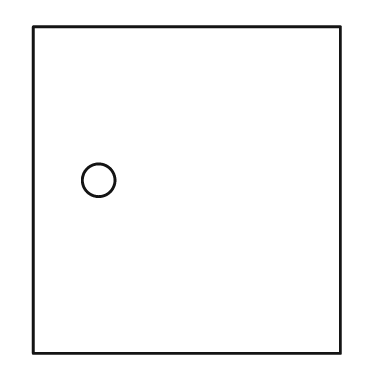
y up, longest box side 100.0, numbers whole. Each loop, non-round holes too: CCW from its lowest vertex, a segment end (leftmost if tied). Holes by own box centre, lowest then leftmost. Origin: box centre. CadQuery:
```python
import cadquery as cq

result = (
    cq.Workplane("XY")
    .moveTo(-47.0, -50.0)
    .lineTo(47.0, -50.0)
    .lineTo(47.0, 50.0)
    .lineTo(-47.0, 50.0)
    .close()
    .moveTo(-27.0, 3.0)
    .circle(5.0)
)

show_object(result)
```